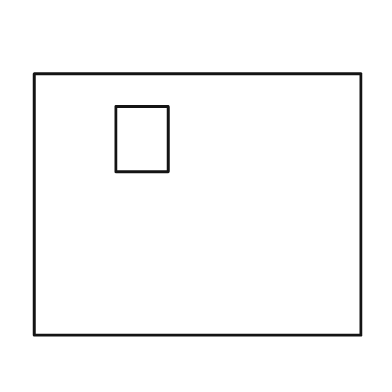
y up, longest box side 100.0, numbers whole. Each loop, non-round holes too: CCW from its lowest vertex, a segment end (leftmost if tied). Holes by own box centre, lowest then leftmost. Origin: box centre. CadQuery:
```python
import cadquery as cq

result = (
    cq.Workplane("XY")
    .moveTo(-50.0, -40.0)
    .lineTo(50.0, -40.0)
    .lineTo(50.0, 40.0)
    .lineTo(-50.0, 40.0)
    .close()
    .moveTo(-25.0, 10.0)
    .lineTo(-9.0, 10.0)
    .lineTo(-9.0, 30.0)
    .lineTo(-25.0, 30.0)
    .close()
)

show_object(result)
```